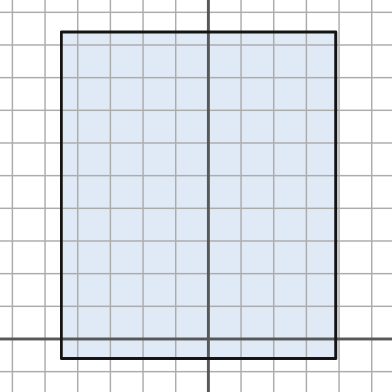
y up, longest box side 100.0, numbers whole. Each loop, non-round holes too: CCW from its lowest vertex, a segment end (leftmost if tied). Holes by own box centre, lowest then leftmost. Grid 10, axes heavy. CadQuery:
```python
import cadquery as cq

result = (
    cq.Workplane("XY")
    .moveTo(-45.0, -6.0)
    .lineTo(39.0, -6.0)
    .lineTo(39.0, 94.0)
    .lineTo(-45.0, 94.0)
    .close()
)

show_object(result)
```